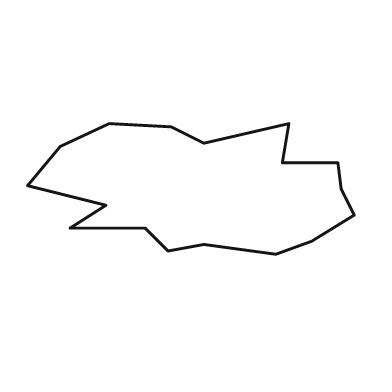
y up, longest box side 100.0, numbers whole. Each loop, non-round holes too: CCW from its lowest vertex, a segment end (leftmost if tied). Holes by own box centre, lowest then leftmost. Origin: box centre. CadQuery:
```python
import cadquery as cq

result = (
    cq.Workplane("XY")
    .moveTo(26.0, -20.0)
    .lineTo(37.0, -16.0)
    .lineTo(50.0, -8.0)
    .lineTo(46.0, 0.0)
    .lineTo(45.0, 8.0)
    .lineTo(28.0, 8.0)
    .lineTo(30.0, 20.0)
    .lineTo(4.0, 14.0)
    .lineTo(-6.0, 19.0)
    .lineTo(-25.0, 20.0)
    .lineTo(-40.0, 13.0)
    .lineTo(-50.0, 1.0)
    .lineTo(-26.0, -5.0)
    .lineTo(-37.0, -12.0)
    .lineTo(-14.0, -12.0)
    .lineTo(-7.0, -19.0)
    .lineTo(4.0, -17.0)
    .close()
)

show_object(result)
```